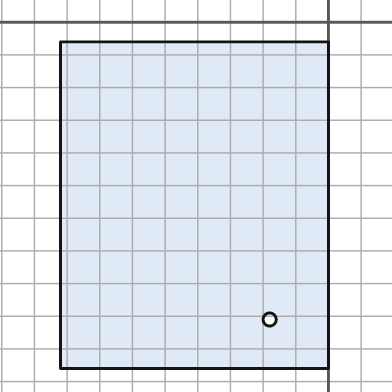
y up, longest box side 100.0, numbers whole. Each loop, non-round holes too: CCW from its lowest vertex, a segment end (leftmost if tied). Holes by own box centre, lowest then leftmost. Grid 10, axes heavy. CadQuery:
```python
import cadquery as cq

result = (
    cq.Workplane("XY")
    .moveTo(-82.0, -106.0)
    .lineTo(0.0, -106.0)
    .lineTo(0.0, -6.0)
    .lineTo(-82.0, -6.0)
    .close()
    .moveTo(-18.0, -91.0)
    .circle(2.0)
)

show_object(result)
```